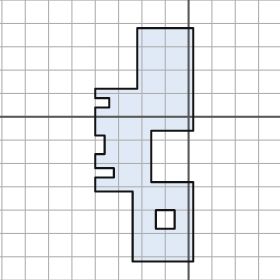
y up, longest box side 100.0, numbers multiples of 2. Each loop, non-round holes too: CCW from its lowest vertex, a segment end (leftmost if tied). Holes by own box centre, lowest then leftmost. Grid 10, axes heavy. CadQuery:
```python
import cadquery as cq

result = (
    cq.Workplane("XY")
    .moveTo(-24.0, -62.0)
    .lineTo(2.0, -62.0)
    .lineTo(2.0, -28.0)
    .lineTo(-16.0, -28.0)
    .lineTo(-16.0, -6.0)
    .lineTo(2.0, -6.0)
    .lineTo(2.0, 38.0)
    .lineTo(-22.0, 38.0)
    .lineTo(-22.0, 12.0)
    .lineTo(-40.0, 12.0)
    .lineTo(-40.0, 8.0)
    .lineTo(-34.0, 8.0)
    .lineTo(-34.0, 4.0)
    .lineTo(-40.0, 4.0)
    .lineTo(-40.0, -8.0)
    .lineTo(-36.0, -8.0)
    .lineTo(-36.0, -16.0)
    .lineTo(-40.0, -16.0)
    .lineTo(-40.0, -22.0)
    .lineTo(-32.0, -22.0)
    .lineTo(-32.0, -26.0)
    .lineTo(-40.0, -26.0)
    .lineTo(-40.0, -32.0)
    .lineTo(-24.0, -32.0)
    .close()
    .moveTo(-14.0, -48.0)
    .lineTo(-6.0, -48.0)
    .lineTo(-6.0, -40.0)
    .lineTo(-14.0, -40.0)
    .close()
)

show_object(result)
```